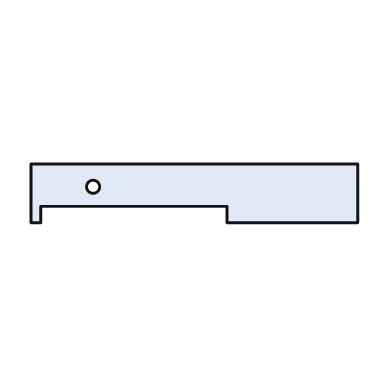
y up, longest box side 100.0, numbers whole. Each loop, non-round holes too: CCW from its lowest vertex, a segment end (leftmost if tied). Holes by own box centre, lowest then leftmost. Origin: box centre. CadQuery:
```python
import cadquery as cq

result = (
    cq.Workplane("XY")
    .moveTo(-50.0, -9.0)
    .lineTo(-47.0, -9.0)
    .lineTo(-47.0, -4.0)
    .lineTo(10.0, -4.0)
    .lineTo(10.0, -9.0)
    .lineTo(50.0, -9.0)
    .lineTo(50.0, 9.0)
    .lineTo(-50.0, 9.0)
    .close()
    .moveTo(-31.0, 2.0)
    .circle(2.0)
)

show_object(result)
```